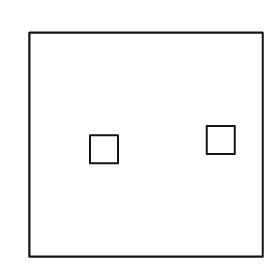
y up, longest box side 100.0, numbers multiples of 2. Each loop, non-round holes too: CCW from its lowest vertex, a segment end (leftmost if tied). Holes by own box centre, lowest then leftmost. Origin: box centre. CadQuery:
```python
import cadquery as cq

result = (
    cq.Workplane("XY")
    .moveTo(-50.0, -48.0)
    .lineTo(50.0, -48.0)
    .lineTo(50.0, 48.0)
    .lineTo(-50.0, 48.0)
    .close()
    .moveTo(-24.0, -8.0)
    .lineTo(-12.0, -8.0)
    .lineTo(-12.0, 4.0)
    .lineTo(-24.0, 4.0)
    .close()
    .moveTo(26.0, -4.0)
    .lineTo(38.0, -4.0)
    .lineTo(38.0, 8.0)
    .lineTo(26.0, 8.0)
    .close()
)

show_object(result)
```